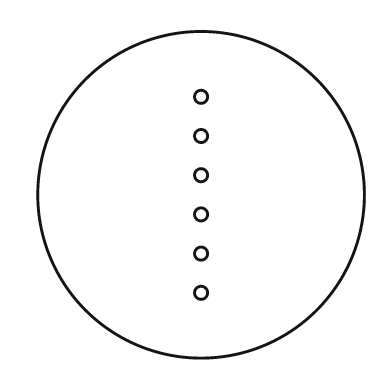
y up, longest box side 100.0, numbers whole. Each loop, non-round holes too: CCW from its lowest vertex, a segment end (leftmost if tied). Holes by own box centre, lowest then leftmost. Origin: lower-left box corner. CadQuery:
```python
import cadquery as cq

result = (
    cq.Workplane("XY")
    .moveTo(50.0, 50.0)
    .circle(50.0)
    .moveTo(50.0, 20.0)
    .circle(2.0)
    .moveTo(50.0, 32.0)
    .circle(2.0)
    .moveTo(50.0, 44.0)
    .circle(2.0)
    .moveTo(50.0, 56.0)
    .circle(2.0)
    .moveTo(50.0, 68.0)
    .circle(2.0)
    .moveTo(50.0, 80.0)
    .circle(2.0)
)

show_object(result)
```